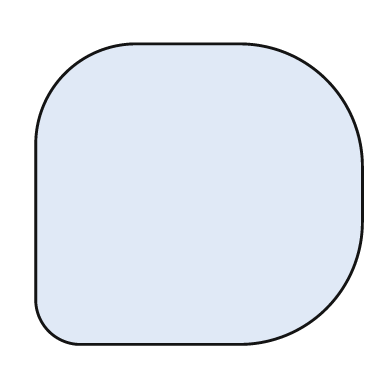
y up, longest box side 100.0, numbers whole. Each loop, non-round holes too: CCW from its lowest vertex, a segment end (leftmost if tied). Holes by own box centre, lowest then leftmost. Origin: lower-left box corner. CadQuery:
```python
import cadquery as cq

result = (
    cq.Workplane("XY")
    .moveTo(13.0, 0.0)
    .lineTo(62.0, 0.0)
    .threePointArc((89.0, 11.0), (100.0, 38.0))
    .lineTo(100.0, 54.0)
    .threePointArc((89.0, 81.0), (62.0, 92.0))
    .lineTo(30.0, 92.0)
    .threePointArc((9.0, 83.0), (0.0, 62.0))
    .lineTo(0.0, 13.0)
    .threePointArc((4.0, 4.0), (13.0, 0.0))
    .close()
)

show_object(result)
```